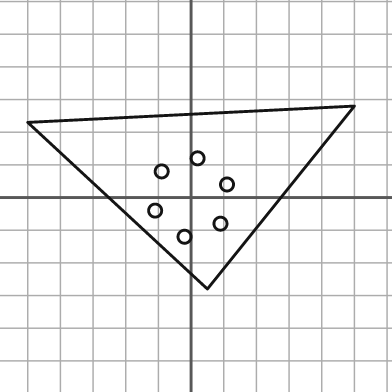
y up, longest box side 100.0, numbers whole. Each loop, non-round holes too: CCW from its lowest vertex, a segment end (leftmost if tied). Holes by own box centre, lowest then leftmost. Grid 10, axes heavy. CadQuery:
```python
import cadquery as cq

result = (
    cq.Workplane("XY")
    .moveTo(5.0, -28.0)
    .lineTo(50.0, 28.0)
    .lineTo(-50.0, 23.0)
    .close()
    .moveTo(-2.0, -12.0)
    .circle(2.0)
    .moveTo(9.0, -8.0)
    .circle(2.0)
    .moveTo(-11.0, -4.0)
    .circle(2.0)
    .moveTo(11.0, 4.0)
    .circle(2.0)
    .moveTo(-9.0, 8.0)
    .circle(2.0)
    .moveTo(2.0, 12.0)
    .circle(2.0)
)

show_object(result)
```